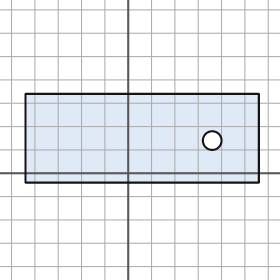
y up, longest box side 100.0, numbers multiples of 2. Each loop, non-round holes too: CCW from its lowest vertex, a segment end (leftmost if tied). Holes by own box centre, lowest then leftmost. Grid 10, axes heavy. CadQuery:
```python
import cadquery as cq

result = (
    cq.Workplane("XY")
    .moveTo(-44.0, -4.0)
    .lineTo(56.0, -4.0)
    .lineTo(56.0, 34.0)
    .lineTo(-44.0, 34.0)
    .close()
    .moveTo(36.0, 14.0)
    .circle(4.0)
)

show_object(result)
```